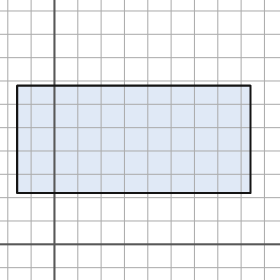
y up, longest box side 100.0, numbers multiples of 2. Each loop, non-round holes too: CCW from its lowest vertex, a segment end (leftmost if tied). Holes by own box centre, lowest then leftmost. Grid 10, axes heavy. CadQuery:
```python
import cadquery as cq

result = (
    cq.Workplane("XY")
    .moveTo(-16.0, 22.0)
    .lineTo(84.0, 22.0)
    .lineTo(84.0, 68.0)
    .lineTo(-16.0, 68.0)
    .close()
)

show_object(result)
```